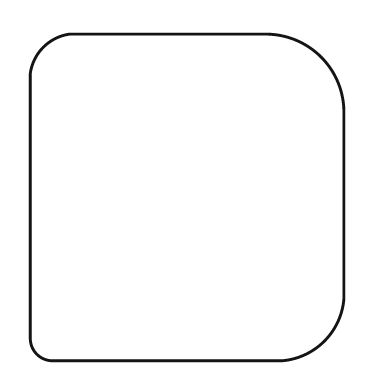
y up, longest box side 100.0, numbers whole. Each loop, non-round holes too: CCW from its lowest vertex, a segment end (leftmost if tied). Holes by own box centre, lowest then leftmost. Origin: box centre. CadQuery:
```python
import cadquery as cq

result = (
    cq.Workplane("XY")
    .moveTo(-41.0, -50.0)
    .lineTo(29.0, -50.0)
    .threePointArc((42.0, -44.0), (48.0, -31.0))
    .lineTo(48.0, 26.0)
    .threePointArc((41.0, 43.0), (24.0, 50.0))
    .lineTo(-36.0, 50.0)
    .threePointArc((-44.0, 46.0), (-48.0, 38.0))
    .lineTo(-48.0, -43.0)
    .threePointArc((-46.0, -48.0), (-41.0, -50.0))
    .close()
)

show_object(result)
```